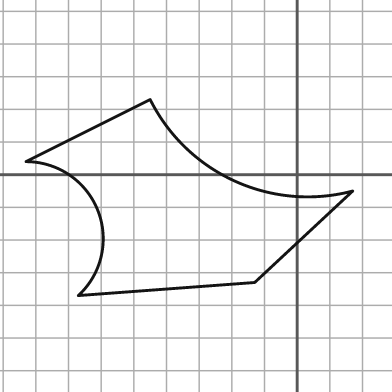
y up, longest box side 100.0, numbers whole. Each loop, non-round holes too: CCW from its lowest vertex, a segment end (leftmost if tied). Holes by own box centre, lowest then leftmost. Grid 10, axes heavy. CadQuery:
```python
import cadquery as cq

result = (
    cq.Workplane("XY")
    .moveTo(-67.0, -37.0)
    .lineTo(-13.0, -33.0)
    .lineTo(17.0, -5.0)
    .threePointArc((-19.0, -2.0), (-45.0, 23.0))
    .lineTo(-83.0, 4.0)
    .threePointArc((-61.0, -11.0), (-67.0, -37.0))
    .close()
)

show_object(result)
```